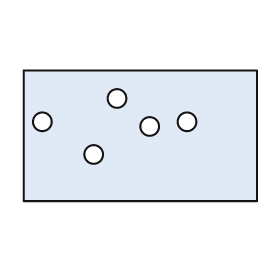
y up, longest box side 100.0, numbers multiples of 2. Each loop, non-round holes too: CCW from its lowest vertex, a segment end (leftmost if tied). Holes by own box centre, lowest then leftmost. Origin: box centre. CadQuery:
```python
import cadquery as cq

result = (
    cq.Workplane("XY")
    .moveTo(-50.0, -28.0)
    .lineTo(50.0, -28.0)
    .lineTo(50.0, 28.0)
    .lineTo(-50.0, 28.0)
    .close()
    .moveTo(-20.0, -8.0)
    .circle(4.0)
    .moveTo(4.0, 4.0)
    .circle(4.0)
    .moveTo(-42.0, 6.0)
    .circle(4.0)
    .moveTo(20.0, 6.0)
    .circle(4.0)
    .moveTo(-10.0, 16.0)
    .circle(4.0)
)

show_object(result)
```